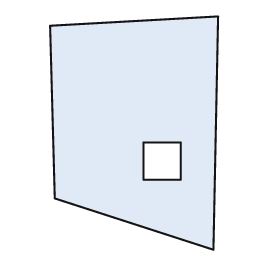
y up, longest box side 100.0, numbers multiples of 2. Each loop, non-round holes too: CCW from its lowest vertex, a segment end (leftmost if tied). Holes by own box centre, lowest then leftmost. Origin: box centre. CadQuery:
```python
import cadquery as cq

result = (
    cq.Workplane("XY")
    .moveTo(34.0, -50.0)
    .lineTo(36.0, 50.0)
    .lineTo(-36.0, 46.0)
    .lineTo(-34.0, -28.0)
    .close()
    .moveTo(4.0, -20.0)
    .lineTo(20.0, -20.0)
    .lineTo(20.0, -4.0)
    .lineTo(4.0, -4.0)
    .close()
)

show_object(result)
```